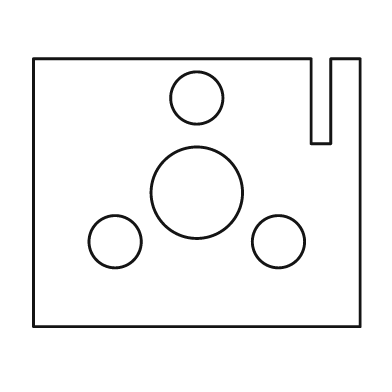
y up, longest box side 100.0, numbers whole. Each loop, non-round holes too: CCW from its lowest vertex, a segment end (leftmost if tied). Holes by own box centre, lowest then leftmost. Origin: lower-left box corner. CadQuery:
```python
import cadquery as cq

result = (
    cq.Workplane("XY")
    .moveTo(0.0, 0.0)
    .lineTo(100.0, 0.0)
    .lineTo(100.0, 82.0)
    .lineTo(91.0, 82.0)
    .lineTo(91.0, 56.0)
    .lineTo(85.0, 56.0)
    .lineTo(85.0, 82.0)
    .lineTo(0.0, 82.0)
    .close()
    .moveTo(25.0, 26.0)
    .circle(8.0)
    .moveTo(75.0, 26.0)
    .circle(8.0)
    .moveTo(50.0, 41.0)
    .circle(14.0)
    .moveTo(50.0, 70.0)
    .circle(8.0)
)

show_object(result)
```